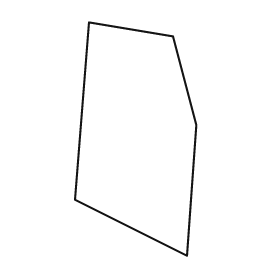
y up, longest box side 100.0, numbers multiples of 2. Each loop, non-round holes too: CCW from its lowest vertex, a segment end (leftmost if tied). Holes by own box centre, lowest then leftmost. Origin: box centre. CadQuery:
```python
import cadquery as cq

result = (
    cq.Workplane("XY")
    .moveTo(22.0, -50.0)
    .lineTo(26.0, 6.0)
    .lineTo(16.0, 44.0)
    .lineTo(-20.0, 50.0)
    .lineTo(-26.0, -26.0)
    .close()
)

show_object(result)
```